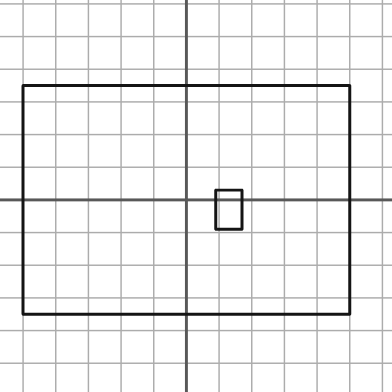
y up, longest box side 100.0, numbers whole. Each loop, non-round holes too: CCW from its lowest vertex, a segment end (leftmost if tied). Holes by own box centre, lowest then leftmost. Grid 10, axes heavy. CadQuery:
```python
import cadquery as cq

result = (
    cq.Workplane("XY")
    .moveTo(-50.0, -35.0)
    .lineTo(50.0, -35.0)
    .lineTo(50.0, 35.0)
    .lineTo(-50.0, 35.0)
    .close()
    .moveTo(9.0, -9.0)
    .lineTo(17.0, -9.0)
    .lineTo(17.0, 3.0)
    .lineTo(9.0, 3.0)
    .close()
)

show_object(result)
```